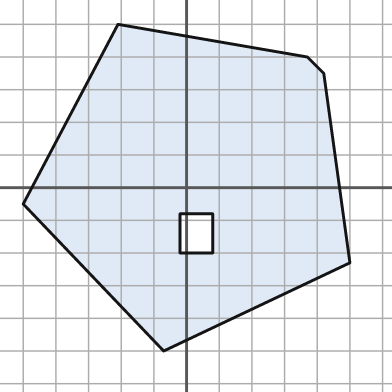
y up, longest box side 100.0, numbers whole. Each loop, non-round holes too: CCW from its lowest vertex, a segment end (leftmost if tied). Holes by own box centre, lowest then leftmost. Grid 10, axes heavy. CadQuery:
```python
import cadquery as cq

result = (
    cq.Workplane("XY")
    .moveTo(-7.0, -50.0)
    .lineTo(50.0, -23.0)
    .lineTo(42.0, 35.0)
    .lineTo(37.0, 40.0)
    .lineTo(-21.0, 50.0)
    .lineTo(-50.0, -5.0)
    .close()
    .moveTo(-2.0, -20.0)
    .lineTo(8.0, -20.0)
    .lineTo(8.0, -8.0)
    .lineTo(-2.0, -8.0)
    .close()
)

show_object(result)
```